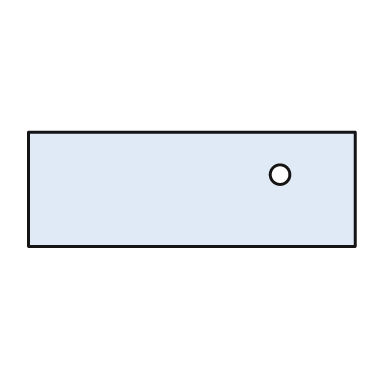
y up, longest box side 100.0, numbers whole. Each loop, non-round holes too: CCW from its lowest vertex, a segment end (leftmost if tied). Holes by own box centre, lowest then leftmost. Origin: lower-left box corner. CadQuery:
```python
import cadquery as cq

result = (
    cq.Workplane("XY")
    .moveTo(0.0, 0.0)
    .lineTo(100.0, 0.0)
    .lineTo(100.0, 35.0)
    .lineTo(0.0, 35.0)
    .close()
    .moveTo(77.0, 22.0)
    .circle(3.0)
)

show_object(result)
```